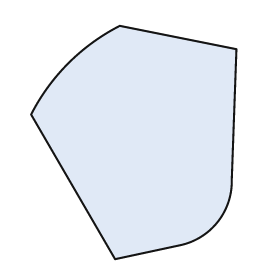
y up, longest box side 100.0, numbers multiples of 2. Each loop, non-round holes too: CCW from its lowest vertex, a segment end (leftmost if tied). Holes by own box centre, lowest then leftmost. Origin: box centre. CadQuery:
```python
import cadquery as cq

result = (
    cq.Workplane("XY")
    .moveTo(-8.0, -50.0)
    .lineTo(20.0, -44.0)
    .threePointArc((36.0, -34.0), (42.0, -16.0))
    .lineTo(44.0, 40.0)
    .lineTo(-6.0, 50.0)
    .threePointArc((-28.0, 34.0), (-44.0, 12.0))
    .close()
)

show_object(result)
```